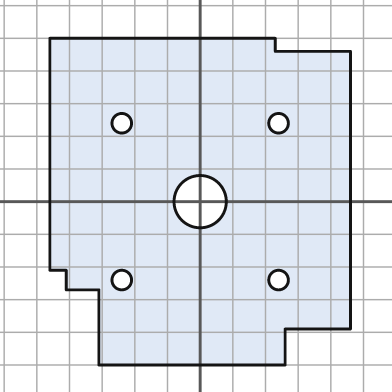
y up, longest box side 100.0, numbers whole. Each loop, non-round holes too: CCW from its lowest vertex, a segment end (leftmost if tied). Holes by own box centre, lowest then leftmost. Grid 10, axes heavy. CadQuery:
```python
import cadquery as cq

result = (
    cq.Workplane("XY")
    .moveTo(-31.0, -50.0)
    .lineTo(26.0, -50.0)
    .lineTo(26.0, -39.0)
    .lineTo(46.0, -39.0)
    .lineTo(46.0, 46.0)
    .lineTo(23.0, 46.0)
    .lineTo(23.0, 50.0)
    .lineTo(-46.0, 50.0)
    .lineTo(-46.0, -21.0)
    .lineTo(-41.0, -21.0)
    .lineTo(-41.0, -27.0)
    .lineTo(-31.0, -27.0)
    .close()
    .moveTo(-24.0, -24.0)
    .circle(3.0)
    .moveTo(24.0, -24.0)
    .circle(3.0)
    .moveTo(0.0, 0.0)
    .circle(8.0)
    .moveTo(-24.0, 24.0)
    .circle(3.0)
    .moveTo(24.0, 24.0)
    .circle(3.0)
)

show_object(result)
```